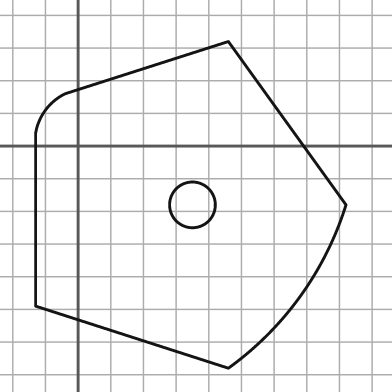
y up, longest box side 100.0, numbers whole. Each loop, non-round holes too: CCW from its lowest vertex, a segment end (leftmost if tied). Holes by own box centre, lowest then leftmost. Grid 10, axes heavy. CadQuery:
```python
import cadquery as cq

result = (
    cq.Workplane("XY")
    .moveTo(46.0, -68.0)
    .threePointArc((68.0, -46.0), (82.0, -18.0))
    .lineTo(46.0, 32.0)
    .lineTo(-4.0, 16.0)
    .threePointArc((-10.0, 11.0), (-13.0, 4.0))
    .lineTo(-13.0, -49.0)
    .close()
    .moveTo(35.0, -18.0)
    .circle(7.0)
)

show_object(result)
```